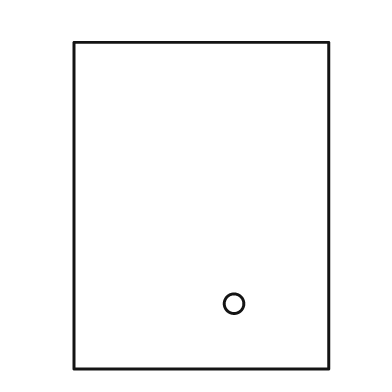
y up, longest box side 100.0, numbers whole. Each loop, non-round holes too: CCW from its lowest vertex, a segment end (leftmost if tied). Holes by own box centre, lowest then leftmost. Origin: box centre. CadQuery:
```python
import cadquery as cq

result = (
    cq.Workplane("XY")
    .moveTo(-39.0, -50.0)
    .lineTo(39.0, -50.0)
    .lineTo(39.0, 50.0)
    .lineTo(-39.0, 50.0)
    .close()
    .moveTo(10.0, -30.0)
    .circle(3.0)
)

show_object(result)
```